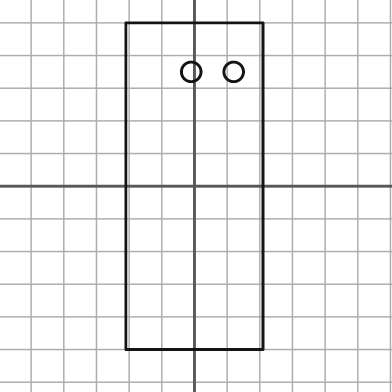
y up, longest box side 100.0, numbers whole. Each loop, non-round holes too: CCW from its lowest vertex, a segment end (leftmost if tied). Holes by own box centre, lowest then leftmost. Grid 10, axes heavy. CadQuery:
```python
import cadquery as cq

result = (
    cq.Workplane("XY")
    .moveTo(-21.0, -50.0)
    .lineTo(21.0, -50.0)
    .lineTo(21.0, 50.0)
    .lineTo(-21.0, 50.0)
    .close()
    .moveTo(-1.0, 35.0)
    .circle(3.0)
    .moveTo(12.0, 35.0)
    .circle(3.0)
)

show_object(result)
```